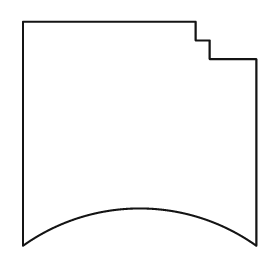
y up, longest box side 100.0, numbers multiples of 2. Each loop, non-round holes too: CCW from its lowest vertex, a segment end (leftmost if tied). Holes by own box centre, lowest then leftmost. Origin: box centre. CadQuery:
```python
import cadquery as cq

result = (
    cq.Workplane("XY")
    .moveTo(-50.0, -48.0)
    .threePointArc((0.0, -32.0), (50.0, -48.0))
    .lineTo(50.0, 32.0)
    .lineTo(30.0, 32.0)
    .lineTo(30.0, 40.0)
    .lineTo(24.0, 40.0)
    .lineTo(24.0, 48.0)
    .lineTo(-50.0, 48.0)
    .close()
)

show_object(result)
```